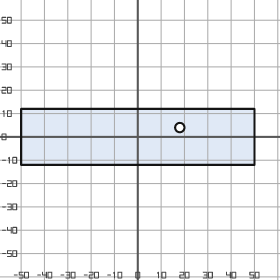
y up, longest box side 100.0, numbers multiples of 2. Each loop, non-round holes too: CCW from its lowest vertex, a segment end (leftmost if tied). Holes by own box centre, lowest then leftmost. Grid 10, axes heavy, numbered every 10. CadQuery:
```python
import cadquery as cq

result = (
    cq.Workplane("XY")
    .moveTo(-50.0, -12.0)
    .lineTo(50.0, -12.0)
    .lineTo(50.0, 12.0)
    .lineTo(-50.0, 12.0)
    .close()
    .moveTo(18.0, 4.0)
    .circle(2.0)
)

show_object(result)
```